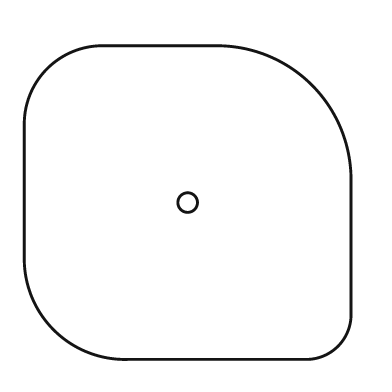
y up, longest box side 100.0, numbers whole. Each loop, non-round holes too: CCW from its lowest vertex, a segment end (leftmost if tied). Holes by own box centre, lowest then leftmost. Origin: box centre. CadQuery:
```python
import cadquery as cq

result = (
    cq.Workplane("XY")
    .moveTo(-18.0, -48.0)
    .lineTo(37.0, -48.0)
    .threePointArc((46.0, -44.0), (50.0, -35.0))
    .lineTo(50.0, 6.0)
    .threePointArc((38.0, 36.0), (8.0, 48.0))
    .lineTo(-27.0, 48.0)
    .threePointArc((-43.0, 41.0), (-50.0, 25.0))
    .lineTo(-50.0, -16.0)
    .threePointArc((-41.0, -39.0), (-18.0, -48.0))
    .close()
    .moveTo(0.0, 0.0)
    .circle(3.0)
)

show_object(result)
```